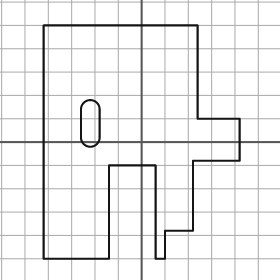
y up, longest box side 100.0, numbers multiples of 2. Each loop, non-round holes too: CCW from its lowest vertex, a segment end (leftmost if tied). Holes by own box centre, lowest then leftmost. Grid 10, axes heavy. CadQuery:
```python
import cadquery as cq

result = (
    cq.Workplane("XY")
    .moveTo(-42.0, -50.0)
    .lineTo(-14.0, -50.0)
    .lineTo(-14.0, -10.0)
    .lineTo(6.0, -10.0)
    .lineTo(6.0, -50.0)
    .lineTo(10.0, -50.0)
    .lineTo(10.0, -38.0)
    .lineTo(22.0, -38.0)
    .lineTo(22.0, -8.0)
    .lineTo(42.0, -8.0)
    .lineTo(42.0, 10.0)
    .lineTo(24.0, 10.0)
    .lineTo(24.0, 50.0)
    .lineTo(-42.0, 50.0)
    .close()
    .moveTo(-26.0, 2.0)
    .threePointArc((-22.0, -2.0), (-18.0, 2.0))
    .lineTo(-18.0, 14.0)
    .threePointArc((-22.0, 18.0), (-26.0, 14.0))
    .close()
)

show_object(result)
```